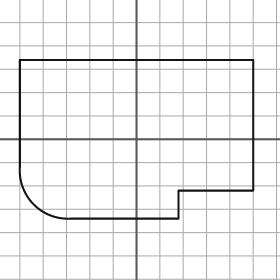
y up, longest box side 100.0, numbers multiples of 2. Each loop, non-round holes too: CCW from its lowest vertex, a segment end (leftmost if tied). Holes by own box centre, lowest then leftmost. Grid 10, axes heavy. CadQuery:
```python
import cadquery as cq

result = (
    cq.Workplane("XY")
    .moveTo(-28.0, -34.0)
    .lineTo(18.0, -34.0)
    .lineTo(18.0, -22.0)
    .lineTo(50.0, -22.0)
    .lineTo(50.0, 34.0)
    .lineTo(-50.0, 34.0)
    .lineTo(-50.0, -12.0)
    .threePointArc((-44.0, -28.0), (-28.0, -34.0))
    .close()
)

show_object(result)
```